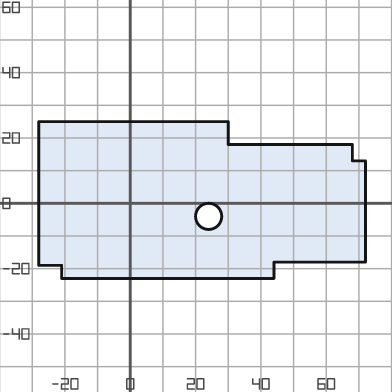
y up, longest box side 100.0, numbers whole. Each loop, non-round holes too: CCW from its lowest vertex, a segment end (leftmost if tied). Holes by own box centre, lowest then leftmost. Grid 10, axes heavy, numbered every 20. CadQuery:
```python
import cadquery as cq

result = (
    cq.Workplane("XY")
    .moveTo(-21.0, -23.0)
    .lineTo(44.0, -23.0)
    .lineTo(44.0, -18.0)
    .lineTo(72.0, -18.0)
    .lineTo(72.0, 13.0)
    .lineTo(68.0, 13.0)
    .lineTo(68.0, 18.0)
    .lineTo(30.0, 18.0)
    .lineTo(30.0, 25.0)
    .lineTo(-28.0, 25.0)
    .lineTo(-28.0, -19.0)
    .lineTo(-21.0, -19.0)
    .close()
    .moveTo(24.0, -4.0)
    .circle(4.0)
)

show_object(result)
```